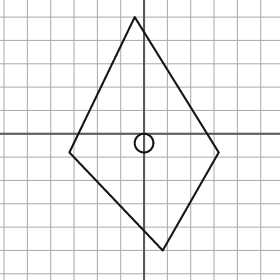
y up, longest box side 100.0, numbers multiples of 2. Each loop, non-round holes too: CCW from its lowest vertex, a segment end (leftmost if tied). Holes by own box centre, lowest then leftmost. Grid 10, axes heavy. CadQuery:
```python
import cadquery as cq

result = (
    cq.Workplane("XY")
    .moveTo(8.0, -50.0)
    .lineTo(32.0, -8.0)
    .lineTo(-4.0, 50.0)
    .lineTo(-32.0, -8.0)
    .close()
    .moveTo(0.0, -4.0)
    .circle(4.0)
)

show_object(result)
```